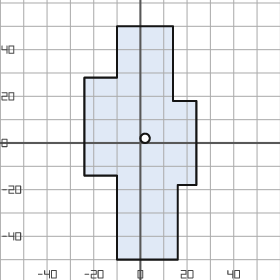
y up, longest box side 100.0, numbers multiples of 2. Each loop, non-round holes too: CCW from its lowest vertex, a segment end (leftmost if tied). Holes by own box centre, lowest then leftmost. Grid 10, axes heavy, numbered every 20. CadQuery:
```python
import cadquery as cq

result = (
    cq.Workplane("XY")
    .moveTo(-10.0, -50.0)
    .lineTo(16.0, -50.0)
    .lineTo(16.0, -18.0)
    .lineTo(24.0, -18.0)
    .lineTo(24.0, 18.0)
    .lineTo(14.0, 18.0)
    .lineTo(14.0, 50.0)
    .lineTo(-10.0, 50.0)
    .lineTo(-10.0, 28.0)
    .lineTo(-24.0, 28.0)
    .lineTo(-24.0, -14.0)
    .lineTo(-10.0, -14.0)
    .close()
    .moveTo(2.0, 2.0)
    .circle(2.0)
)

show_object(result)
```